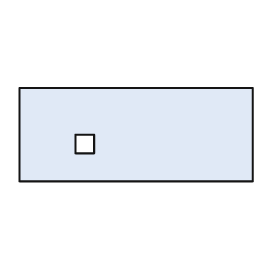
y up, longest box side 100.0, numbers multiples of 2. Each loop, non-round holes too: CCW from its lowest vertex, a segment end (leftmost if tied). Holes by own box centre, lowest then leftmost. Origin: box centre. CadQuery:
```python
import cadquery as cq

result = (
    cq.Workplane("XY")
    .moveTo(-50.0, -20.0)
    .lineTo(50.0, -20.0)
    .lineTo(50.0, 20.0)
    .lineTo(-50.0, 20.0)
    .close()
    .moveTo(-26.0, -8.0)
    .lineTo(-18.0, -8.0)
    .lineTo(-18.0, 0.0)
    .lineTo(-26.0, 0.0)
    .close()
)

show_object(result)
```